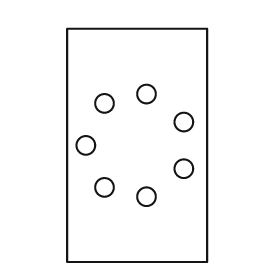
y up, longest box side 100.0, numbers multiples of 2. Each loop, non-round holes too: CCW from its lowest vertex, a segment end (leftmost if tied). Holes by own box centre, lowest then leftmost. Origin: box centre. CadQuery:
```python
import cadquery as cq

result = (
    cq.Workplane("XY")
    .moveTo(-30.0, -50.0)
    .lineTo(30.0, -50.0)
    .lineTo(30.0, 50.0)
    .lineTo(-30.0, 50.0)
    .close()
    .moveTo(4.0, -22.0)
    .circle(4.0)
    .moveTo(-14.0, -18.0)
    .circle(4.0)
    .moveTo(20.0, -10.0)
    .circle(4.0)
    .moveTo(-22.0, 0.0)
    .circle(4.0)
    .moveTo(20.0, 10.0)
    .circle(4.0)
    .moveTo(-14.0, 18.0)
    .circle(4.0)
    .moveTo(4.0, 22.0)
    .circle(4.0)
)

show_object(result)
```